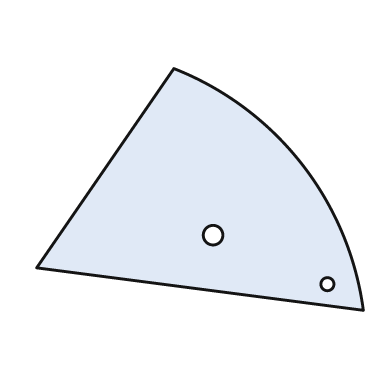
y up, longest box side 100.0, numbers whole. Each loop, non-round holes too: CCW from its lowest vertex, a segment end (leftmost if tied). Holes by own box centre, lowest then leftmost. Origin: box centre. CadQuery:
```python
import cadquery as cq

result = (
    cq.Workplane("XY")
    .moveTo(50.0, -37.0)
    .threePointArc((31.0, 8.0), (-8.0, 37.0))
    .lineTo(-50.0, -24.0)
    .close()
    .moveTo(39.0, -29.0)
    .circle(2.0)
    .moveTo(4.0, -14.0)
    .circle(3.0)
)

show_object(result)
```